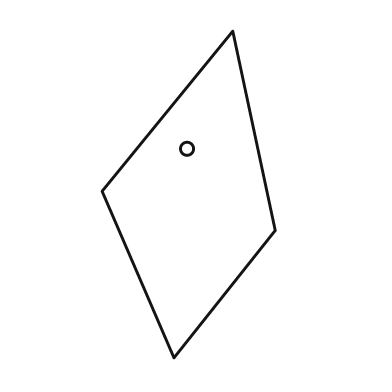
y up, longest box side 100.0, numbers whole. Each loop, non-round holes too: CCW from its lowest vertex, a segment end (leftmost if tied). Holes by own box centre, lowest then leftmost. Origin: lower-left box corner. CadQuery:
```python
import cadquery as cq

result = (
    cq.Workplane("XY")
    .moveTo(22.0, 0.0)
    .lineTo(53.0, 39.0)
    .lineTo(40.0, 100.0)
    .lineTo(0.0, 51.0)
    .close()
    .moveTo(26.0, 64.0)
    .circle(2.0)
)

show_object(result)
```